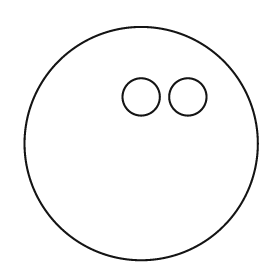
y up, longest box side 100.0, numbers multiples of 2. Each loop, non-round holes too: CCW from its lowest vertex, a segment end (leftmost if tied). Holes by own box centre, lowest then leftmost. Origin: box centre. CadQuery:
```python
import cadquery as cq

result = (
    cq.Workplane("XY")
    .moveTo(0.0, 0.0)
    .circle(50.0)
    .moveTo(0.0, 20.0)
    .circle(8.0)
    .moveTo(20.0, 20.0)
    .circle(8.0)
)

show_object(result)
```